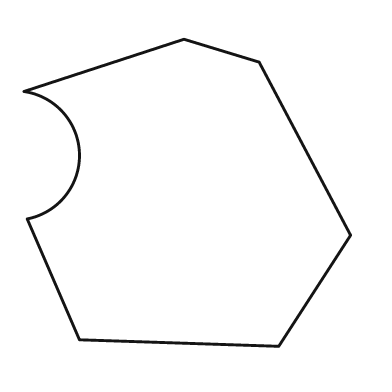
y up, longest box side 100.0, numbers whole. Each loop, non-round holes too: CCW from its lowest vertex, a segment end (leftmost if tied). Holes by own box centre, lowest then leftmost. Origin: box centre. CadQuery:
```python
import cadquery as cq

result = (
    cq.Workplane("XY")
    .moveTo(28.0, -47.0)
    .lineTo(50.0, -13.0)
    .lineTo(22.0, 40.0)
    .lineTo(-1.0, 47.0)
    .lineTo(-50.0, 31.0)
    .threePointArc((-33.0, 12.0), (-49.0, -8.0))
    .lineTo(-33.0, -45.0)
    .close()
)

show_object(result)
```